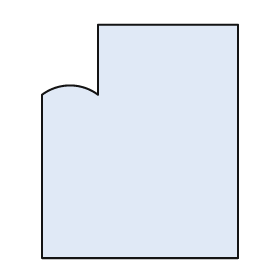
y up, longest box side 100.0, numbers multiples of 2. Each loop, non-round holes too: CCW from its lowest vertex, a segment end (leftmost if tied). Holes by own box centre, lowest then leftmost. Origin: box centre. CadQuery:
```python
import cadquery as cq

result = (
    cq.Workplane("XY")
    .moveTo(-42.0, -50.0)
    .lineTo(42.0, -50.0)
    .lineTo(42.0, 50.0)
    .lineTo(-18.0, 50.0)
    .lineTo(-18.0, 20.0)
    .threePointArc((-30.0, 24.0), (-42.0, 20.0))
    .close()
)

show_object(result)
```